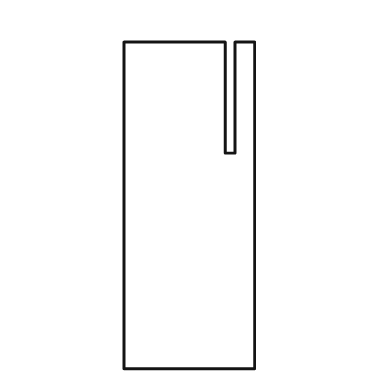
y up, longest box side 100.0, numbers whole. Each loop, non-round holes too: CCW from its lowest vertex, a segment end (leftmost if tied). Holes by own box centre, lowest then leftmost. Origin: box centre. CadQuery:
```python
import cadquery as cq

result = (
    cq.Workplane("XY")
    .moveTo(-20.0, -50.0)
    .lineTo(20.0, -50.0)
    .lineTo(20.0, 50.0)
    .lineTo(14.0, 50.0)
    .lineTo(14.0, 16.0)
    .lineTo(11.0, 16.0)
    .lineTo(11.0, 50.0)
    .lineTo(-20.0, 50.0)
    .close()
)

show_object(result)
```